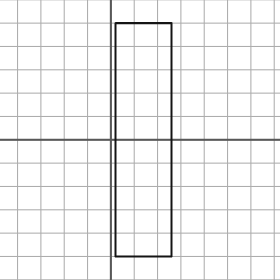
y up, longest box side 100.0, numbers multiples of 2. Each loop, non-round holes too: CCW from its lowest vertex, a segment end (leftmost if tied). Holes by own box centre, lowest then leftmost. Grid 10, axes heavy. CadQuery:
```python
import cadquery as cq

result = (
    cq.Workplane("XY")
    .moveTo(2.0, -50.0)
    .lineTo(26.0, -50.0)
    .lineTo(26.0, 50.0)
    .lineTo(2.0, 50.0)
    .close()
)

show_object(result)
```